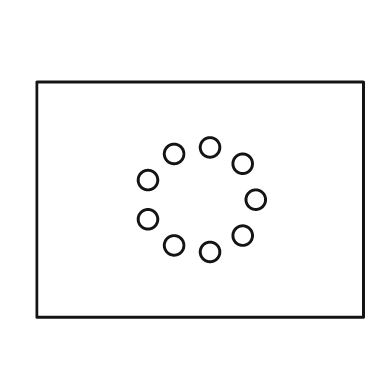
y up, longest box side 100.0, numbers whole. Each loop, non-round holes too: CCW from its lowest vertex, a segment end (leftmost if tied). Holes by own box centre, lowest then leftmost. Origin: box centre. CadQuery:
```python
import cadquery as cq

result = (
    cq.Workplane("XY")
    .moveTo(-50.0, -36.0)
    .lineTo(50.0, -36.0)
    .lineTo(50.0, 36.0)
    .lineTo(-50.0, 36.0)
    .close()
    .moveTo(3.0, -16.0)
    .circle(3.0)
    .moveTo(-8.0, -14.0)
    .circle(3.0)
    .moveTo(13.0, -11.0)
    .circle(3.0)
    .moveTo(-16.0, -6.0)
    .circle(3.0)
    .moveTo(17.0, 0.0)
    .circle(3.0)
    .moveTo(-16.0, 6.0)
    .circle(3.0)
    .moveTo(13.0, 11.0)
    .circle(3.0)
    .moveTo(-8.0, 14.0)
    .circle(3.0)
    .moveTo(3.0, 16.0)
    .circle(3.0)
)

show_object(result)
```